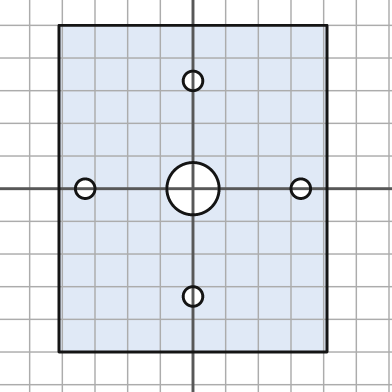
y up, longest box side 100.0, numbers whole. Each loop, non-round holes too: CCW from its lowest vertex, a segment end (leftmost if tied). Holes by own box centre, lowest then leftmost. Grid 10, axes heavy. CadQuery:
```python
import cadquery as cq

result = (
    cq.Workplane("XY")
    .moveTo(-41.0, -50.0)
    .lineTo(41.0, -50.0)
    .lineTo(41.0, 50.0)
    .lineTo(-41.0, 50.0)
    .close()
    .moveTo(0.0, -33.0)
    .circle(3.0)
    .moveTo(-33.0, 0.0)
    .circle(3.0)
    .moveTo(0.0, 0.0)
    .circle(8.0)
    .moveTo(33.0, 0.0)
    .circle(3.0)
    .moveTo(0.0, 33.0)
    .circle(3.0)
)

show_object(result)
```